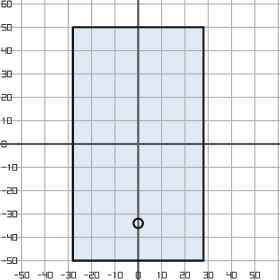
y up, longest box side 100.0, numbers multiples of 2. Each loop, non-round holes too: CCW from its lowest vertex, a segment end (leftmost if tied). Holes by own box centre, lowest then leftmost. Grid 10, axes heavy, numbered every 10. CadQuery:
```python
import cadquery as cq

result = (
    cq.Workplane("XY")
    .moveTo(-28.0, -50.0)
    .lineTo(28.0, -50.0)
    .lineTo(28.0, 50.0)
    .lineTo(-28.0, 50.0)
    .close()
    .moveTo(0.0, -34.0)
    .circle(2.0)
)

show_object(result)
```